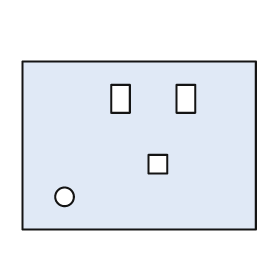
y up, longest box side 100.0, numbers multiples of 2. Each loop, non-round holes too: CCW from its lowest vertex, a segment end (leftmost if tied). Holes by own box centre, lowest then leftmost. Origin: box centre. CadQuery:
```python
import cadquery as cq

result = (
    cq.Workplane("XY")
    .moveTo(-50.0, -36.0)
    .lineTo(50.0, -36.0)
    .lineTo(50.0, 36.0)
    .lineTo(-50.0, 36.0)
    .close()
    .moveTo(-32.0, -22.0)
    .circle(4.0)
    .moveTo(4.0, -12.0)
    .lineTo(12.0, -12.0)
    .lineTo(12.0, -4.0)
    .lineTo(4.0, -4.0)
    .close()
    .moveTo(-12.0, 14.0)
    .lineTo(-4.0, 14.0)
    .lineTo(-4.0, 26.0)
    .lineTo(-12.0, 26.0)
    .close()
    .moveTo(16.0, 14.0)
    .lineTo(24.0, 14.0)
    .lineTo(24.0, 26.0)
    .lineTo(16.0, 26.0)
    .close()
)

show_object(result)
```